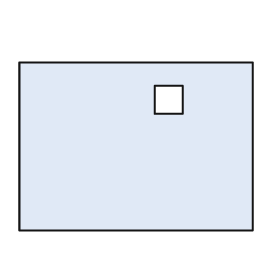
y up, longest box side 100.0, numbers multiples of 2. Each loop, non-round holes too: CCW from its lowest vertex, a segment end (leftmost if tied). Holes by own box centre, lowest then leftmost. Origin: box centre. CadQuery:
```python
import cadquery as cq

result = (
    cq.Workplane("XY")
    .moveTo(-50.0, -36.0)
    .lineTo(50.0, -36.0)
    .lineTo(50.0, 36.0)
    .lineTo(-50.0, 36.0)
    .close()
    .moveTo(8.0, 14.0)
    .lineTo(20.0, 14.0)
    .lineTo(20.0, 26.0)
    .lineTo(8.0, 26.0)
    .close()
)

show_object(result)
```